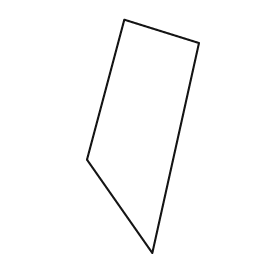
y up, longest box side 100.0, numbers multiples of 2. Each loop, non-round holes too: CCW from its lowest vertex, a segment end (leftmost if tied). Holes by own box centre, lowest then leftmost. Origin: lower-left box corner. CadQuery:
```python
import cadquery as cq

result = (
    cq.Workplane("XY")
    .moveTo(28.0, 0.0)
    .lineTo(48.0, 90.0)
    .lineTo(16.0, 100.0)
    .lineTo(0.0, 40.0)
    .close()
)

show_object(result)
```